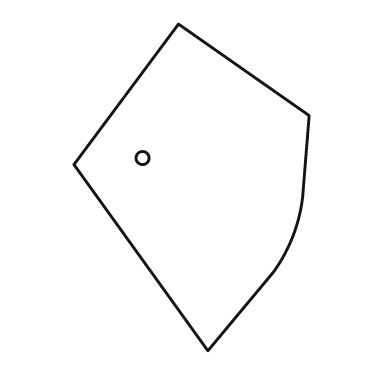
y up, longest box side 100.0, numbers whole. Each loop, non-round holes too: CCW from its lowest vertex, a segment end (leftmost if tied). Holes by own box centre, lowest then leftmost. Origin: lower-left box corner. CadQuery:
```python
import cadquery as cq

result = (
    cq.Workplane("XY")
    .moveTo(41.0, 0.0)
    .lineTo(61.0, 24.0)
    .threePointArc((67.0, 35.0), (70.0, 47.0))
    .lineTo(72.0, 72.0)
    .lineTo(32.0, 100.0)
    .lineTo(0.0, 57.0)
    .close()
    .moveTo(21.0, 59.0)
    .circle(2.0)
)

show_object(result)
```